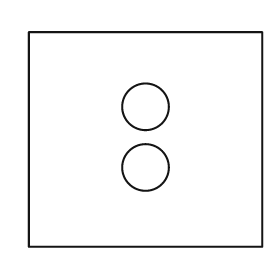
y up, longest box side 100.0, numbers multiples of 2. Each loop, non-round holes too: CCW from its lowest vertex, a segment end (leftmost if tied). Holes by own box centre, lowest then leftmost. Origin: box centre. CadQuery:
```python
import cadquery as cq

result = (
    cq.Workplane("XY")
    .moveTo(-50.0, -46.0)
    .lineTo(50.0, -46.0)
    .lineTo(50.0, 46.0)
    .lineTo(-50.0, 46.0)
    .close()
    .moveTo(0.0, -12.0)
    .circle(10.0)
    .moveTo(0.0, 14.0)
    .circle(10.0)
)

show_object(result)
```